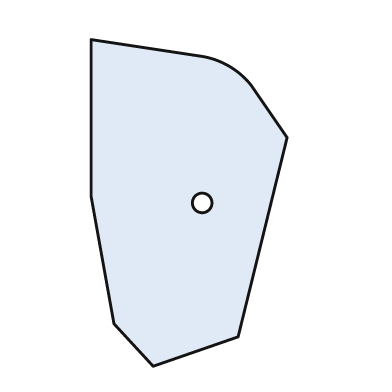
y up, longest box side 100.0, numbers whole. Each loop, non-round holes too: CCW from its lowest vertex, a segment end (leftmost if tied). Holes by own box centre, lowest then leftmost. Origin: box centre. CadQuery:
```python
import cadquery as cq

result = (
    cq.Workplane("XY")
    .moveTo(-11.0, -50.0)
    .lineTo(15.0, -41.0)
    .lineTo(30.0, 20.0)
    .lineTo(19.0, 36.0)
    .threePointArc((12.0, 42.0), (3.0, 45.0))
    .lineTo(-30.0, 50.0)
    .lineTo(-30.0, 2.0)
    .lineTo(-23.0, -37.0)
    .close()
    .moveTo(4.0, 0.0)
    .circle(3.0)
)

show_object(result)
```